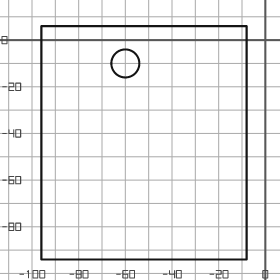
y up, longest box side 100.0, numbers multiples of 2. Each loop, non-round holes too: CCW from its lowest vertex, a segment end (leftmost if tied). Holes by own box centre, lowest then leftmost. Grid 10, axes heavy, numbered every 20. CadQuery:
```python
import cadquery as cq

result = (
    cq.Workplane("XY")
    .moveTo(-96.0, -94.0)
    .lineTo(-8.0, -94.0)
    .lineTo(-8.0, 6.0)
    .lineTo(-96.0, 6.0)
    .close()
    .moveTo(-60.0, -10.0)
    .circle(6.0)
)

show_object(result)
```